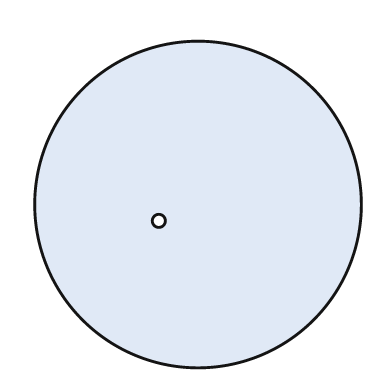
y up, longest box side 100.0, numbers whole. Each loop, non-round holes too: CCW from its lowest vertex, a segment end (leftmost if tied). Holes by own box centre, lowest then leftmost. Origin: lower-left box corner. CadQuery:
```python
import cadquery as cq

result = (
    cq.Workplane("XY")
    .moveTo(50.0, 50.0)
    .circle(50.0)
    .moveTo(38.0, 45.0)
    .circle(2.0)
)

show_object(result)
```